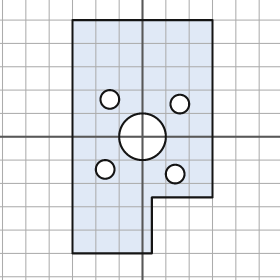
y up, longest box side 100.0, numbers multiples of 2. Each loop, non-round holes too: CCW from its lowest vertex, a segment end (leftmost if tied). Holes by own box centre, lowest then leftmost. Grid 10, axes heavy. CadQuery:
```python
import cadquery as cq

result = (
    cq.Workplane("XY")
    .moveTo(-30.0, -50.0)
    .lineTo(4.0, -50.0)
    .lineTo(4.0, -26.0)
    .lineTo(30.0, -26.0)
    .lineTo(30.0, 50.0)
    .lineTo(-30.0, 50.0)
    .close()
    .moveTo(14.0, -16.0)
    .circle(4.0)
    .moveTo(-16.0, -14.0)
    .circle(4.0)
    .moveTo(0.0, 0.0)
    .circle(10.0)
    .moveTo(16.0, 14.0)
    .circle(4.0)
    .moveTo(-14.0, 16.0)
    .circle(4.0)
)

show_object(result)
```